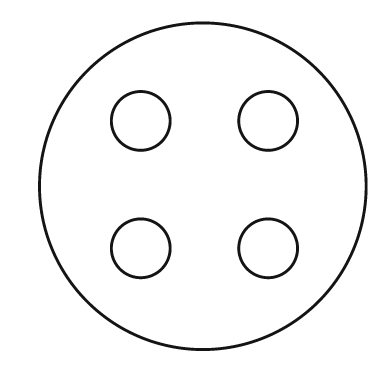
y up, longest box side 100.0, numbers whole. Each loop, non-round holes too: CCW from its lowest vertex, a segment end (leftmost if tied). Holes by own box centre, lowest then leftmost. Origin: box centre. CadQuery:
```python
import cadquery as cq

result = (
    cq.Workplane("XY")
    .moveTo(0.0, 0.0)
    .circle(50.0)
    .moveTo(-19.0, -19.0)
    .circle(9.0)
    .moveTo(20.0, -19.0)
    .circle(9.0)
    .moveTo(-19.0, 20.0)
    .circle(9.0)
    .moveTo(20.0, 20.0)
    .circle(9.0)
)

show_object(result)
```